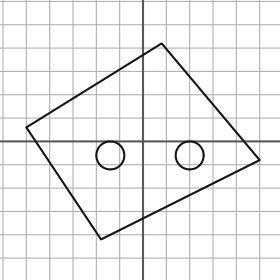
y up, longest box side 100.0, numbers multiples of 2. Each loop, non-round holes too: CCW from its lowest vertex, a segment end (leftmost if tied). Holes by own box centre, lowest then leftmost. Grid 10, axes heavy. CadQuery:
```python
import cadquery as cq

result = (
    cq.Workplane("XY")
    .moveTo(-18.0, -42.0)
    .lineTo(50.0, -8.0)
    .lineTo(8.0, 42.0)
    .lineTo(-50.0, 6.0)
    .close()
    .moveTo(-14.0, -6.0)
    .circle(6.0)
    .moveTo(20.0, -6.0)
    .circle(6.0)
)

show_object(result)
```